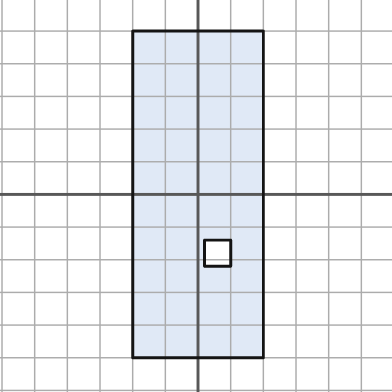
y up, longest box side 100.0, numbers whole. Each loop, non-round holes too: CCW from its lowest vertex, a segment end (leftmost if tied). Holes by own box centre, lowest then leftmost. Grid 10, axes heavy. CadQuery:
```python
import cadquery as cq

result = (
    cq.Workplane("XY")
    .moveTo(-20.0, -50.0)
    .lineTo(20.0, -50.0)
    .lineTo(20.0, 50.0)
    .lineTo(-20.0, 50.0)
    .close()
    .moveTo(2.0, -22.0)
    .lineTo(10.0, -22.0)
    .lineTo(10.0, -14.0)
    .lineTo(2.0, -14.0)
    .close()
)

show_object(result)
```